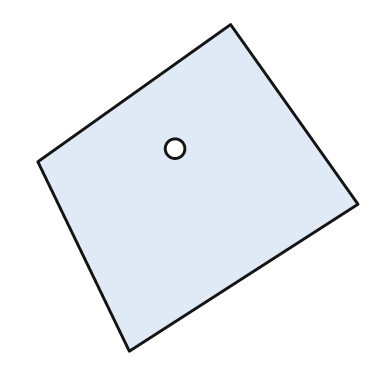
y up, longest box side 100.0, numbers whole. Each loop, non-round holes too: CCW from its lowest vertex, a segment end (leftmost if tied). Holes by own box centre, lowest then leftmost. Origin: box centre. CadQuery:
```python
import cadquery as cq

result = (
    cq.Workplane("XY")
    .moveTo(-21.0, -50.0)
    .lineTo(49.0, -5.0)
    .lineTo(10.0, 50.0)
    .lineTo(-49.0, 8.0)
    .close()
    .moveTo(-7.0, 12.0)
    .circle(3.0)
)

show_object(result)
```